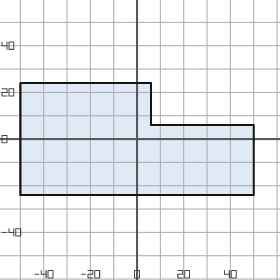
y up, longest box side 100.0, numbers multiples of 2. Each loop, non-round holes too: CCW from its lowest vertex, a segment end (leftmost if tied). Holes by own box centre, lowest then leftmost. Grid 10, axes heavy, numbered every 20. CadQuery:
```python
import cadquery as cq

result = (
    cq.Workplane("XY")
    .moveTo(-50.0, -24.0)
    .lineTo(50.0, -24.0)
    .lineTo(50.0, 6.0)
    .lineTo(6.0, 6.0)
    .lineTo(6.0, 24.0)
    .lineTo(-50.0, 24.0)
    .close()
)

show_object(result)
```